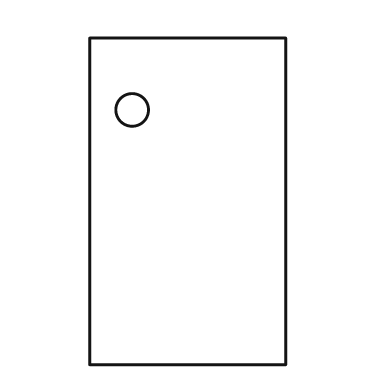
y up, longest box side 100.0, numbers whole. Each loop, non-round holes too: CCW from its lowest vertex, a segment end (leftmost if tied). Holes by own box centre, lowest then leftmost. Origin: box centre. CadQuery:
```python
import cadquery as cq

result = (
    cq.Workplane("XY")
    .moveTo(-30.0, -50.0)
    .lineTo(30.0, -50.0)
    .lineTo(30.0, 50.0)
    .lineTo(-30.0, 50.0)
    .close()
    .moveTo(-17.0, 28.0)
    .circle(5.0)
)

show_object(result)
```